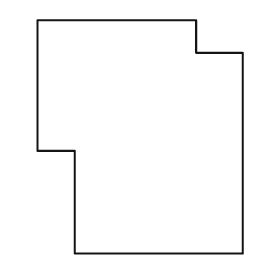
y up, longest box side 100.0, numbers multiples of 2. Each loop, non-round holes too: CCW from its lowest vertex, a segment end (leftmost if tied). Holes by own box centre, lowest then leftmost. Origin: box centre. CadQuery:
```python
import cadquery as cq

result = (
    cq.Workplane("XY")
    .moveTo(-28.0, -50.0)
    .lineTo(44.0, -50.0)
    .lineTo(44.0, 36.0)
    .lineTo(24.0, 36.0)
    .lineTo(24.0, 50.0)
    .lineTo(-44.0, 50.0)
    .lineTo(-44.0, -6.0)
    .lineTo(-28.0, -6.0)
    .close()
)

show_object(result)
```